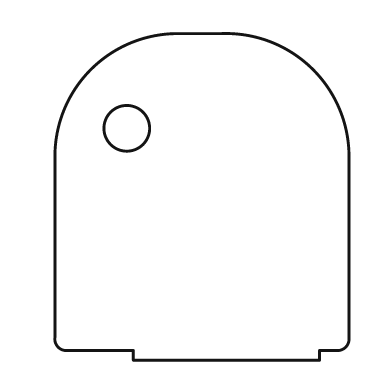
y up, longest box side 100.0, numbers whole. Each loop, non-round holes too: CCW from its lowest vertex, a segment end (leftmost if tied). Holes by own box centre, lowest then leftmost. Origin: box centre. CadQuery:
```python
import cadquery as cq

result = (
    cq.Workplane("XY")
    .moveTo(-21.0, -50.0)
    .lineTo(36.0, -50.0)
    .lineTo(36.0, -47.0)
    .lineTo(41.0, -47.0)
    .threePointArc((44.0, -46.0), (45.0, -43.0))
    .lineTo(45.0, 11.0)
    .threePointArc((34.0, 39.0), (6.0, 50.0))
    .lineTo(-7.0, 50.0)
    .threePointArc((-34.0, 39.0), (-45.0, 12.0))
    .lineTo(-45.0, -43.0)
    .threePointArc((-44.0, -46.0), (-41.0, -47.0))
    .lineTo(-21.0, -47.0)
    .close()
    .moveTo(-23.0, 21.0)
    .circle(7.0)
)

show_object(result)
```